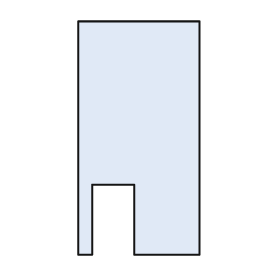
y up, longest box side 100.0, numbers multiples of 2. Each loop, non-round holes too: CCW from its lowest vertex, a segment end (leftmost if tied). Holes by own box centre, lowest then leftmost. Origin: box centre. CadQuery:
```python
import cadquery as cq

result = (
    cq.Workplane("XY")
    .moveTo(-26.0, -50.0)
    .lineTo(-20.0, -50.0)
    .lineTo(-20.0, -20.0)
    .lineTo(-2.0, -20.0)
    .lineTo(-2.0, -50.0)
    .lineTo(26.0, -50.0)
    .lineTo(26.0, 50.0)
    .lineTo(-26.0, 50.0)
    .close()
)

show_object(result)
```